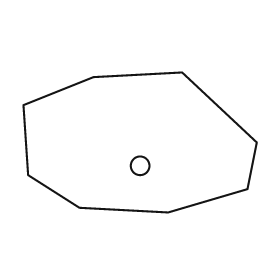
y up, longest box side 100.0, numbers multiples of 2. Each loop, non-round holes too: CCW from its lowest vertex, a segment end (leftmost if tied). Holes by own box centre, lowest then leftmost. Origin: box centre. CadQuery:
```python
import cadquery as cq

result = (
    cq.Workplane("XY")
    .moveTo(12.0, -30.0)
    .lineTo(46.0, -20.0)
    .lineTo(50.0, 0.0)
    .lineTo(18.0, 30.0)
    .lineTo(-20.0, 28.0)
    .lineTo(-50.0, 16.0)
    .lineTo(-48.0, -14.0)
    .lineTo(-26.0, -28.0)
    .close()
    .moveTo(0.0, -10.0)
    .circle(4.0)
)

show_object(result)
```